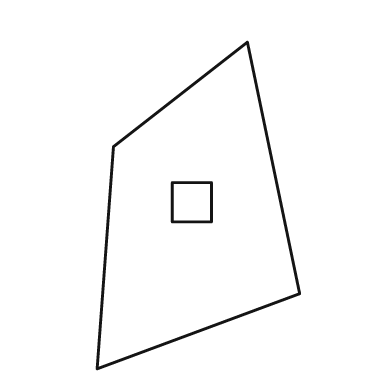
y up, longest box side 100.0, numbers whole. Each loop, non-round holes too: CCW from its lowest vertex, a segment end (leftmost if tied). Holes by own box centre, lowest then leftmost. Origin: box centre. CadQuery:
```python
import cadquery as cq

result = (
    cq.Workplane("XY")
    .moveTo(-31.0, -50.0)
    .lineTo(31.0, -27.0)
    .lineTo(15.0, 50.0)
    .lineTo(-26.0, 18.0)
    .close()
    .moveTo(-8.0, -5.0)
    .lineTo(4.0, -5.0)
    .lineTo(4.0, 7.0)
    .lineTo(-8.0, 7.0)
    .close()
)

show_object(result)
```